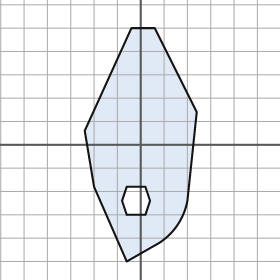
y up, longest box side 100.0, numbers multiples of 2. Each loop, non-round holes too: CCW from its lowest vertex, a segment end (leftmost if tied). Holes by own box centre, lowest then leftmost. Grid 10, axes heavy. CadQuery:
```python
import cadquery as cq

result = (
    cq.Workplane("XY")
    .moveTo(-6.0, -50.0)
    .lineTo(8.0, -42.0)
    .threePointArc((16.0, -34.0), (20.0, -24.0))
    .lineTo(24.0, 14.0)
    .lineTo(6.0, 50.0)
    .lineTo(-4.0, 50.0)
    .lineTo(-24.0, 6.0)
    .lineTo(-20.0, -18.0)
    .close()
    .moveTo(-6.0, -30.0)
    .lineTo(2.0, -30.0)
    .lineTo(4.0, -24.0)
    .lineTo(2.0, -18.0)
    .lineTo(-6.0, -18.0)
    .lineTo(-8.0, -24.0)
    .close()
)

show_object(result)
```